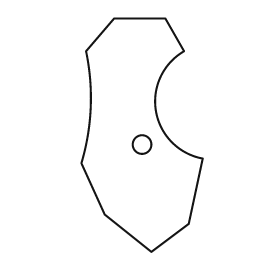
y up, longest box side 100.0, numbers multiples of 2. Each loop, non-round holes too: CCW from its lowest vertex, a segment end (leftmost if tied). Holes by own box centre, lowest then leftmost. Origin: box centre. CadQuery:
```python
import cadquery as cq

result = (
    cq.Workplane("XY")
    .moveTo(4.0, -50.0)
    .lineTo(20.0, -38.0)
    .lineTo(26.0, -10.0)
    .threePointArc((6.0, 10.0), (18.0, 36.0))
    .lineTo(10.0, 50.0)
    .lineTo(-12.0, 50.0)
    .lineTo(-24.0, 36.0)
    .threePointArc((-22.0, 12.0), (-26.0, -12.0))
    .lineTo(-16.0, -34.0)
    .close()
    .moveTo(0.0, -4.0)
    .circle(4.0)
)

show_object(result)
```